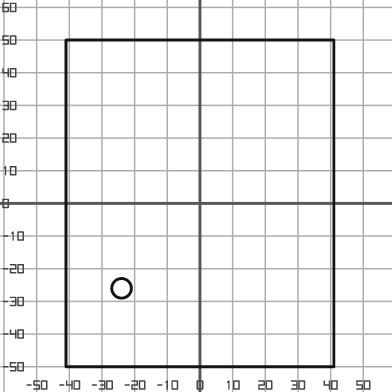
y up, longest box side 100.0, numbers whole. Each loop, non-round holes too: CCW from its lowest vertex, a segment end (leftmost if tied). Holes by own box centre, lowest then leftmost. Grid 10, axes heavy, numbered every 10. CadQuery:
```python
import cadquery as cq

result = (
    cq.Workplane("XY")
    .moveTo(-41.0, -50.0)
    .lineTo(41.0, -50.0)
    .lineTo(41.0, 50.0)
    .lineTo(-41.0, 50.0)
    .close()
    .moveTo(-24.0, -26.0)
    .circle(3.0)
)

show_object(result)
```